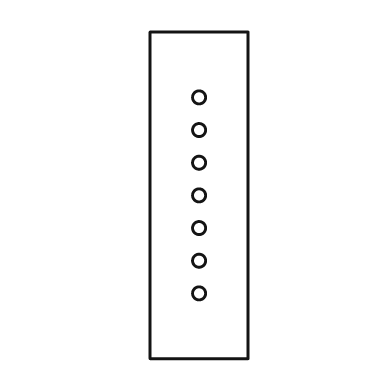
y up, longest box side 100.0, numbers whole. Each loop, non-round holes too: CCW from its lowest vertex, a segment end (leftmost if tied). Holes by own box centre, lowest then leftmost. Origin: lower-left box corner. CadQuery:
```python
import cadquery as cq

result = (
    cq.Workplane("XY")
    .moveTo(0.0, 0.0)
    .lineTo(30.0, 0.0)
    .lineTo(30.0, 100.0)
    .lineTo(0.0, 100.0)
    .close()
    .moveTo(15.0, 20.0)
    .circle(2.0)
    .moveTo(15.0, 30.0)
    .circle(2.0)
    .moveTo(15.0, 40.0)
    .circle(2.0)
    .moveTo(15.0, 50.0)
    .circle(2.0)
    .moveTo(15.0, 60.0)
    .circle(2.0)
    .moveTo(15.0, 70.0)
    .circle(2.0)
    .moveTo(15.0, 80.0)
    .circle(2.0)
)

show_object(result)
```